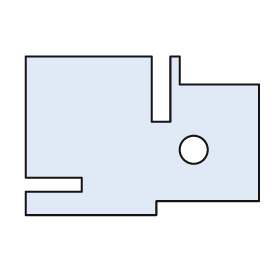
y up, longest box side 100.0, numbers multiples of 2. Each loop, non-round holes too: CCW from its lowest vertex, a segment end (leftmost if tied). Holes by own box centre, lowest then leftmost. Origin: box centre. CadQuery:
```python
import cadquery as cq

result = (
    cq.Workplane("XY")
    .moveTo(-50.0, -34.0)
    .lineTo(6.0, -34.0)
    .lineTo(6.0, -28.0)
    .lineTo(50.0, -28.0)
    .lineTo(50.0, 22.0)
    .lineTo(16.0, 22.0)
    .lineTo(16.0, 34.0)
    .lineTo(12.0, 34.0)
    .lineTo(12.0, 6.0)
    .lineTo(4.0, 6.0)
    .lineTo(4.0, 34.0)
    .lineTo(-50.0, 34.0)
    .lineTo(-50.0, -18.0)
    .lineTo(-26.0, -18.0)
    .lineTo(-26.0, -24.0)
    .lineTo(-50.0, -24.0)
    .close()
    .moveTo(22.0, -6.0)
    .circle(6.0)
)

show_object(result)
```